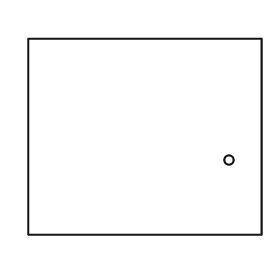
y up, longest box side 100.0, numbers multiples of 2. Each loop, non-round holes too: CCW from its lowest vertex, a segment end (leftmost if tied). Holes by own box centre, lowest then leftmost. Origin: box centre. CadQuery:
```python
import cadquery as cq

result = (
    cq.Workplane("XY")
    .moveTo(-50.0, -42.0)
    .lineTo(50.0, -42.0)
    .lineTo(50.0, 42.0)
    .lineTo(-50.0, 42.0)
    .close()
    .moveTo(36.0, -10.0)
    .circle(2.0)
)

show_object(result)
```